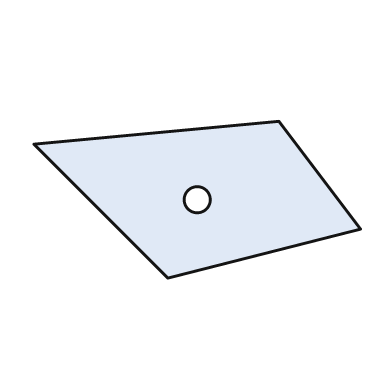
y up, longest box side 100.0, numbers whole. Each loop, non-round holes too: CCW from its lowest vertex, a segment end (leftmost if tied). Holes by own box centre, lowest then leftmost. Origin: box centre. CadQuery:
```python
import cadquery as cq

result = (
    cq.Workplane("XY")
    .moveTo(-9.0, -24.0)
    .lineTo(50.0, -9.0)
    .lineTo(25.0, 24.0)
    .lineTo(-50.0, 17.0)
    .close()
    .moveTo(0.0, 0.0)
    .circle(4.0)
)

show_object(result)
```